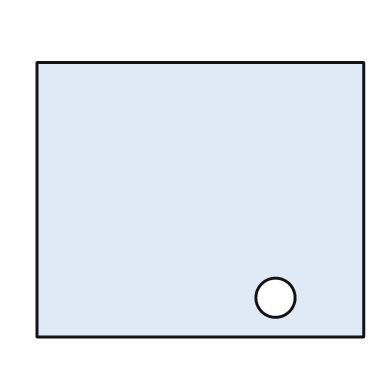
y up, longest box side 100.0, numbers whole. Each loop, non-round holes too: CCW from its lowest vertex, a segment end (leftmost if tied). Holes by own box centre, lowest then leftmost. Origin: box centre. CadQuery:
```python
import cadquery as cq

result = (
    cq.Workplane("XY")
    .moveTo(-50.0, -42.0)
    .lineTo(50.0, -42.0)
    .lineTo(50.0, 42.0)
    .lineTo(-50.0, 42.0)
    .close()
    .moveTo(23.0, -30.0)
    .circle(6.0)
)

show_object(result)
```